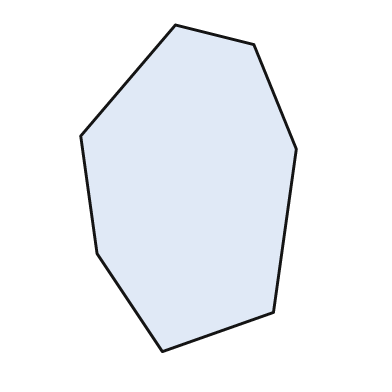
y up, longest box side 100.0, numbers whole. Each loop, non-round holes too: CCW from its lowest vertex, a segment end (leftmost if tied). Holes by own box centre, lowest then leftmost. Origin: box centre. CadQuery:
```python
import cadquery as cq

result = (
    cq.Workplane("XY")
    .moveTo(-8.0, -50.0)
    .lineTo(26.0, -38.0)
    .lineTo(33.0, 12.0)
    .lineTo(20.0, 44.0)
    .lineTo(-4.0, 50.0)
    .lineTo(-33.0, 16.0)
    .lineTo(-28.0, -20.0)
    .close()
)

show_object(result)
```